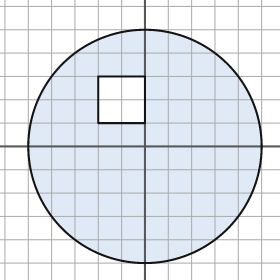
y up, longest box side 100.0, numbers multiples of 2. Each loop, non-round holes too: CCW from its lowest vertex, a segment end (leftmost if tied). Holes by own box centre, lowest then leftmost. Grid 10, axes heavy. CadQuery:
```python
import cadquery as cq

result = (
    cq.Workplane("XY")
    .moveTo(0.0, 0.0)
    .circle(50.0)
    .moveTo(-20.0, 10.0)
    .lineTo(0.0, 10.0)
    .lineTo(0.0, 30.0)
    .lineTo(-20.0, 30.0)
    .close()
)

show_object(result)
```